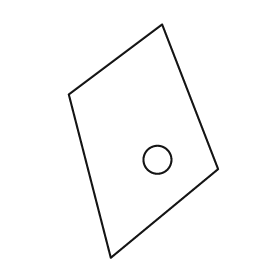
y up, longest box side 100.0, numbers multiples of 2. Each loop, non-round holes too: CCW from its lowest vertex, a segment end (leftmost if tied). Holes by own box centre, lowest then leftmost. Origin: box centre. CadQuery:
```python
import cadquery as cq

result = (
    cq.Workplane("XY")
    .moveTo(-14.0, -50.0)
    .lineTo(32.0, -12.0)
    .lineTo(8.0, 50.0)
    .lineTo(-32.0, 20.0)
    .close()
    .moveTo(6.0, -8.0)
    .circle(6.0)
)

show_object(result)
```